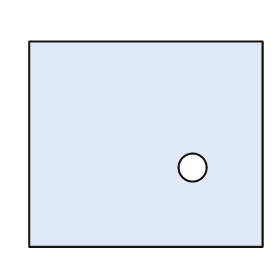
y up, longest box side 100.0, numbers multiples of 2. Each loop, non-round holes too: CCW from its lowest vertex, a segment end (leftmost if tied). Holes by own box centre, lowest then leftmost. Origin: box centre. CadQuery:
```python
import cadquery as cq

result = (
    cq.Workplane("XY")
    .moveTo(-50.0, -44.0)
    .lineTo(50.0, -44.0)
    .lineTo(50.0, 44.0)
    .lineTo(-50.0, 44.0)
    .close()
    .moveTo(20.0, -10.0)
    .circle(6.0)
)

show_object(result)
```